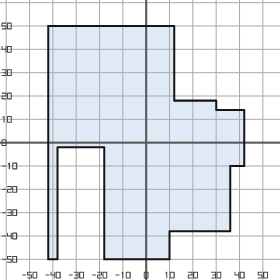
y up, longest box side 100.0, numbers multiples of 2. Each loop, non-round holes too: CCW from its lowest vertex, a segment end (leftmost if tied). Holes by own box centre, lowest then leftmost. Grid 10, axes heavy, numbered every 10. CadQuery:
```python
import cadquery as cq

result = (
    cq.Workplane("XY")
    .moveTo(-42.0, -50.0)
    .lineTo(-38.0, -50.0)
    .lineTo(-38.0, -2.0)
    .lineTo(-18.0, -2.0)
    .lineTo(-18.0, -50.0)
    .lineTo(10.0, -50.0)
    .lineTo(10.0, -38.0)
    .lineTo(36.0, -38.0)
    .lineTo(36.0, -10.0)
    .lineTo(42.0, -10.0)
    .lineTo(42.0, 14.0)
    .lineTo(30.0, 14.0)
    .lineTo(30.0, 18.0)
    .lineTo(12.0, 18.0)
    .lineTo(12.0, 50.0)
    .lineTo(-42.0, 50.0)
    .close()
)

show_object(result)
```